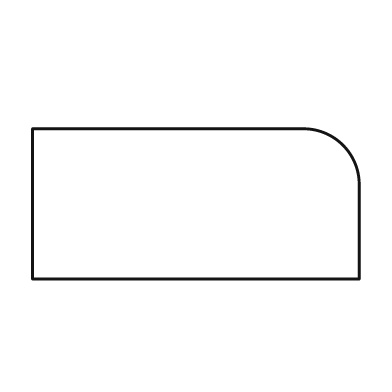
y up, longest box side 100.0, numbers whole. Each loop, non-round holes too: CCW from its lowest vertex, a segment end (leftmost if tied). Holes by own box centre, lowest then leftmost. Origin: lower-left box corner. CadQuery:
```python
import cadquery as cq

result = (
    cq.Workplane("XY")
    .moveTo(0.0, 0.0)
    .lineTo(100.0, 0.0)
    .lineTo(100.0, 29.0)
    .threePointArc((95.0, 41.0), (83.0, 46.0))
    .lineTo(0.0, 46.0)
    .close()
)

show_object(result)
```